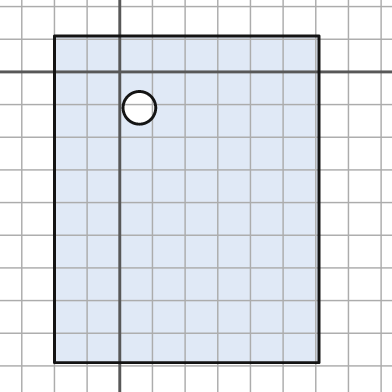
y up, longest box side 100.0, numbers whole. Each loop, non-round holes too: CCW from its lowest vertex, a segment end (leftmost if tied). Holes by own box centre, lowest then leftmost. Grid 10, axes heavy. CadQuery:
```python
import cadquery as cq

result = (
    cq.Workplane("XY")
    .moveTo(-20.0, -89.0)
    .lineTo(61.0, -89.0)
    .lineTo(61.0, 11.0)
    .lineTo(-20.0, 11.0)
    .close()
    .moveTo(6.0, -11.0)
    .circle(5.0)
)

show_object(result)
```